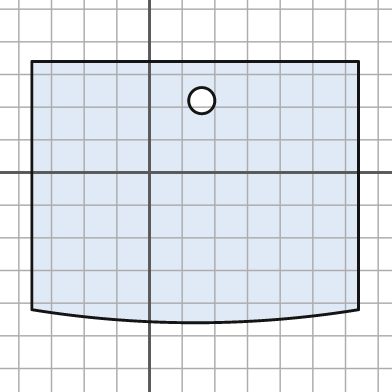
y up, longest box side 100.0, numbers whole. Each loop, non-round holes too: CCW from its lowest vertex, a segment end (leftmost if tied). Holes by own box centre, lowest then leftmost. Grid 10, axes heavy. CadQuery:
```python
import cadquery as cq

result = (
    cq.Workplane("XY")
    .moveTo(-36.0, -42.0)
    .threePointArc((14.0, -46.0), (64.0, -42.0))
    .lineTo(64.0, 34.0)
    .lineTo(-36.0, 34.0)
    .close()
    .moveTo(16.0, 22.0)
    .circle(4.0)
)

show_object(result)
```